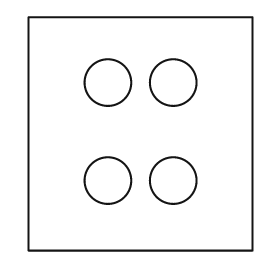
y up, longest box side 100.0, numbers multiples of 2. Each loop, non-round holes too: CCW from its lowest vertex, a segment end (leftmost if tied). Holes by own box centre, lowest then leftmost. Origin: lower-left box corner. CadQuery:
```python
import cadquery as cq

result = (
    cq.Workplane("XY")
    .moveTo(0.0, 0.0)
    .lineTo(96.0, 0.0)
    .lineTo(96.0, 100.0)
    .lineTo(0.0, 100.0)
    .close()
    .moveTo(34.0, 30.0)
    .circle(10.0)
    .moveTo(62.0, 30.0)
    .circle(10.0)
    .moveTo(34.0, 72.0)
    .circle(10.0)
    .moveTo(62.0, 72.0)
    .circle(10.0)
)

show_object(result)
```